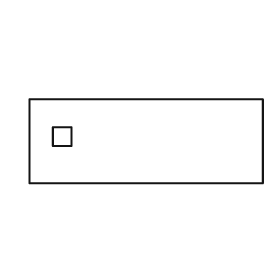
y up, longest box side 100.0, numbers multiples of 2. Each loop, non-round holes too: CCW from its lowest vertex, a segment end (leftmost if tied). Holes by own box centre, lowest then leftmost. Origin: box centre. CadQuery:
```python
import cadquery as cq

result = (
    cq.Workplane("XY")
    .moveTo(-50.0, -18.0)
    .lineTo(50.0, -18.0)
    .lineTo(50.0, 18.0)
    .lineTo(-50.0, 18.0)
    .close()
    .moveTo(-40.0, -2.0)
    .lineTo(-32.0, -2.0)
    .lineTo(-32.0, 6.0)
    .lineTo(-40.0, 6.0)
    .close()
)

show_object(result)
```